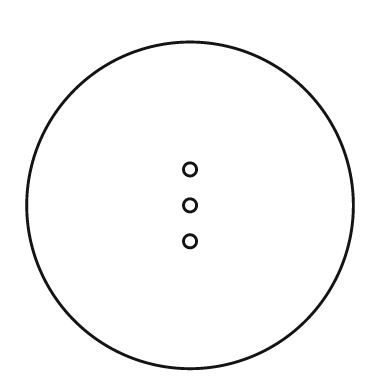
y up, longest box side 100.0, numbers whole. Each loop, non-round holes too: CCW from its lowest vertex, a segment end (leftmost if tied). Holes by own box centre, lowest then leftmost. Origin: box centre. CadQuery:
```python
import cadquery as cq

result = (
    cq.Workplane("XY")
    .moveTo(0.0, 0.0)
    .circle(50.0)
    .moveTo(0.0, -11.0)
    .circle(2.0)
    .moveTo(0.0, 0.0)
    .circle(2.0)
    .moveTo(0.0, 11.0)
    .circle(2.0)
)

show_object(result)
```